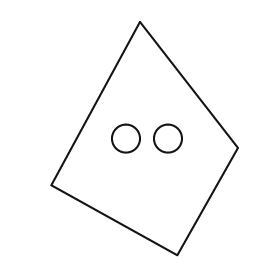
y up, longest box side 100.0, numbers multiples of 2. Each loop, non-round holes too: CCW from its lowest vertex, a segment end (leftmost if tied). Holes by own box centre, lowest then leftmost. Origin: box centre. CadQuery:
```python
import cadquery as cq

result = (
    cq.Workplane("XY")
    .moveTo(14.0, -50.0)
    .lineTo(40.0, -4.0)
    .lineTo(-2.0, 50.0)
    .lineTo(-40.0, -20.0)
    .close()
    .moveTo(-8.0, 0.0)
    .circle(6.0)
    .moveTo(10.0, 0.0)
    .circle(6.0)
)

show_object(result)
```